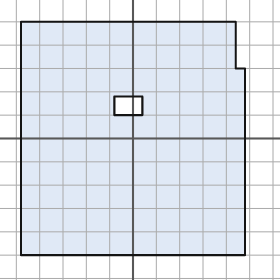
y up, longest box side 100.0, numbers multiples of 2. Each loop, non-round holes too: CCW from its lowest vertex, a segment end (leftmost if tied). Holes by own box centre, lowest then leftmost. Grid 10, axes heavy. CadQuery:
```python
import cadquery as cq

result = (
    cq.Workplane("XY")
    .moveTo(-48.0, -50.0)
    .lineTo(48.0, -50.0)
    .lineTo(48.0, 30.0)
    .lineTo(44.0, 30.0)
    .lineTo(44.0, 50.0)
    .lineTo(-48.0, 50.0)
    .close()
    .moveTo(-8.0, 10.0)
    .lineTo(4.0, 10.0)
    .lineTo(4.0, 18.0)
    .lineTo(-8.0, 18.0)
    .close()
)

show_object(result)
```